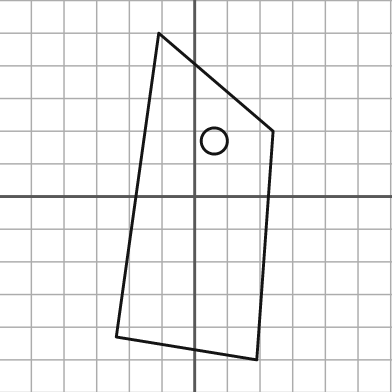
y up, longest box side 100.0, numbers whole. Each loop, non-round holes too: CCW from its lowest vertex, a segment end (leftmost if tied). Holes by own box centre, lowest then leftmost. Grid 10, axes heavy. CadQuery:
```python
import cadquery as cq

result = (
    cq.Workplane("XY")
    .moveTo(19.0, -50.0)
    .lineTo(24.0, 20.0)
    .lineTo(-11.0, 50.0)
    .lineTo(-24.0, -43.0)
    .close()
    .moveTo(6.0, 17.0)
    .circle(4.0)
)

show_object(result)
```